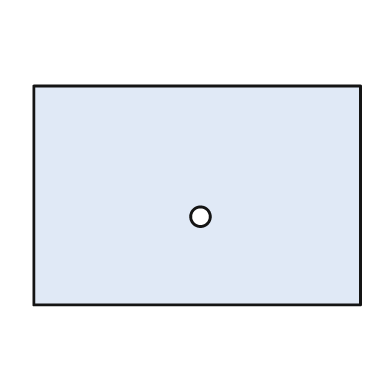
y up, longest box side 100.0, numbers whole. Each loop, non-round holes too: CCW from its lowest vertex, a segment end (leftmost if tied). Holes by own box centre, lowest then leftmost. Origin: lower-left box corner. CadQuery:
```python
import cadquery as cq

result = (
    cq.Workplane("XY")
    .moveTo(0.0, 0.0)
    .lineTo(100.0, 0.0)
    .lineTo(100.0, 67.0)
    .lineTo(0.0, 67.0)
    .close()
    .moveTo(51.0, 27.0)
    .circle(3.0)
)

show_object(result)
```